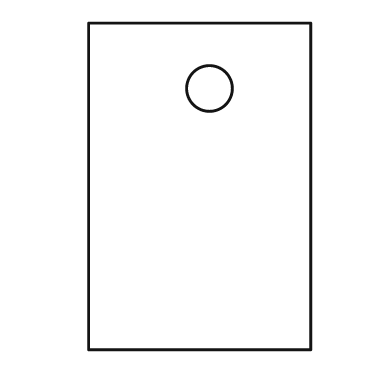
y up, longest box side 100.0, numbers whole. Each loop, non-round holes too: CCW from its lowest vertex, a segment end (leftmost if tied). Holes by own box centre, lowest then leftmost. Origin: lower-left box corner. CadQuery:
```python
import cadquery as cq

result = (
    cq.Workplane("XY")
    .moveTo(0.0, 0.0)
    .lineTo(68.0, 0.0)
    .lineTo(68.0, 100.0)
    .lineTo(0.0, 100.0)
    .close()
    .moveTo(37.0, 80.0)
    .circle(7.0)
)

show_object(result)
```